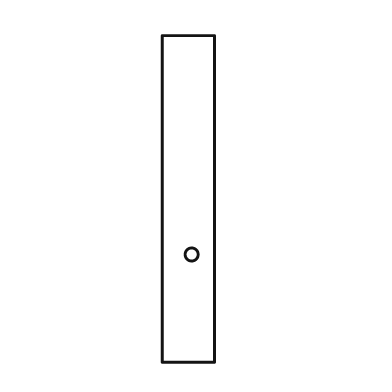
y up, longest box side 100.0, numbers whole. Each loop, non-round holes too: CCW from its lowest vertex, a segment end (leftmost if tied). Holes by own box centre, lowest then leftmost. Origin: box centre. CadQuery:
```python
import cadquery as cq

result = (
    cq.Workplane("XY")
    .moveTo(-8.0, -50.0)
    .lineTo(8.0, -50.0)
    .lineTo(8.0, 50.0)
    .lineTo(-8.0, 50.0)
    .close()
    .moveTo(1.0, -17.0)
    .circle(2.0)
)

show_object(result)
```